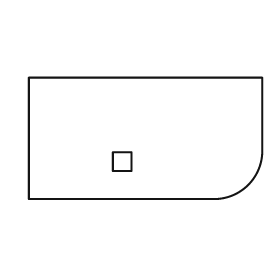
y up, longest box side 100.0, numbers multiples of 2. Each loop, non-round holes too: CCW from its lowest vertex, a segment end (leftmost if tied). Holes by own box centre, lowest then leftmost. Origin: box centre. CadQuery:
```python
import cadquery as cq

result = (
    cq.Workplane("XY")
    .moveTo(-50.0, -26.0)
    .lineTo(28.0, -26.0)
    .threePointArc((44.0, -20.0), (50.0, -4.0))
    .lineTo(50.0, 26.0)
    .lineTo(-50.0, 26.0)
    .close()
    .moveTo(-14.0, -14.0)
    .lineTo(-6.0, -14.0)
    .lineTo(-6.0, -6.0)
    .lineTo(-14.0, -6.0)
    .close()
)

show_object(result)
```